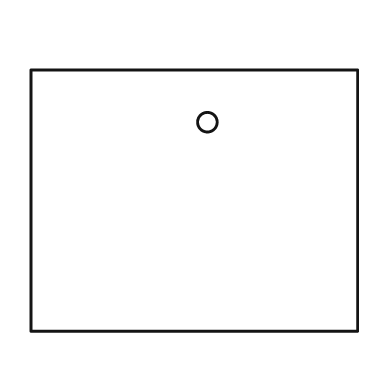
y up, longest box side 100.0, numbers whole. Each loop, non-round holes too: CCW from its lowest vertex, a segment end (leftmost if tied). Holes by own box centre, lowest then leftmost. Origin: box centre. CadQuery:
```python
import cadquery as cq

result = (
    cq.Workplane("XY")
    .moveTo(-50.0, -40.0)
    .lineTo(50.0, -40.0)
    .lineTo(50.0, 40.0)
    .lineTo(-50.0, 40.0)
    .close()
    .moveTo(4.0, 24.0)
    .circle(3.0)
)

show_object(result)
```